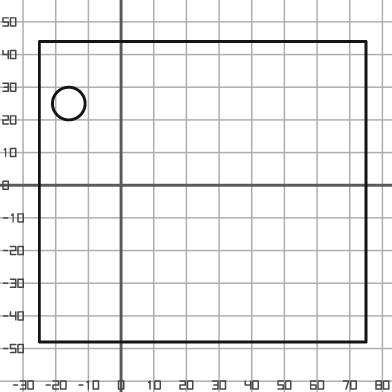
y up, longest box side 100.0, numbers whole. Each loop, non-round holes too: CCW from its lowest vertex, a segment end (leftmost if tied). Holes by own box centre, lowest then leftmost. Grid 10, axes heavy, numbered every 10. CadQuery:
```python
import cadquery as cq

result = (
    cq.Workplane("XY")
    .moveTo(-25.0, -48.0)
    .lineTo(75.0, -48.0)
    .lineTo(75.0, 44.0)
    .lineTo(-25.0, 44.0)
    .close()
    .moveTo(-16.0, 25.0)
    .circle(5.0)
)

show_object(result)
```